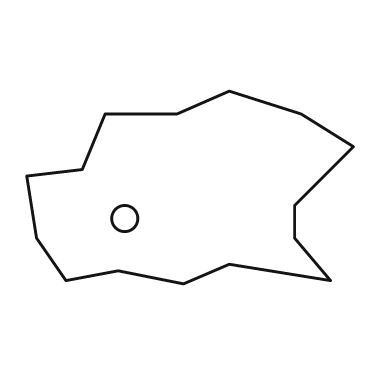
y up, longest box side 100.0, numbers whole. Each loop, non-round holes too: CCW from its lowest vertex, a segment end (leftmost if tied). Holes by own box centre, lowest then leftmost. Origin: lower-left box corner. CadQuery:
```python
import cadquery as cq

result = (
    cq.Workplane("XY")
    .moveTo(48.0, 0.0)
    .lineTo(62.0, 6.0)
    .lineTo(93.0, 1.0)
    .lineTo(82.0, 14.0)
    .lineTo(82.0, 24.0)
    .lineTo(100.0, 42.0)
    .lineTo(84.0, 52.0)
    .lineTo(62.0, 59.0)
    .lineTo(46.0, 52.0)
    .lineTo(24.0, 52.0)
    .lineTo(17.0, 35.0)
    .lineTo(0.0, 33.0)
    .lineTo(3.0, 14.0)
    .lineTo(12.0, 1.0)
    .lineTo(28.0, 4.0)
    .close()
    .moveTo(30.0, 20.0)
    .circle(4.0)
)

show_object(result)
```